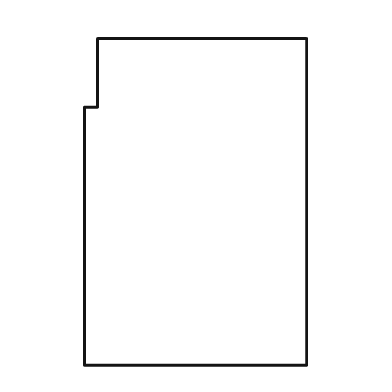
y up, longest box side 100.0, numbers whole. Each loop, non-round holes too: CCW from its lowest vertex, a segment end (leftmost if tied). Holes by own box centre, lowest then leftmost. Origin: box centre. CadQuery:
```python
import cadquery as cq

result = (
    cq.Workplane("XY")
    .moveTo(-34.0, -50.0)
    .lineTo(34.0, -50.0)
    .lineTo(34.0, 50.0)
    .lineTo(-30.0, 50.0)
    .lineTo(-30.0, 29.0)
    .lineTo(-34.0, 29.0)
    .close()
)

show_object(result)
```